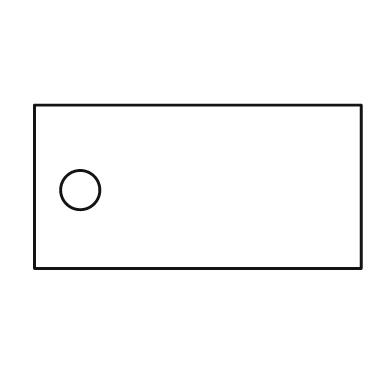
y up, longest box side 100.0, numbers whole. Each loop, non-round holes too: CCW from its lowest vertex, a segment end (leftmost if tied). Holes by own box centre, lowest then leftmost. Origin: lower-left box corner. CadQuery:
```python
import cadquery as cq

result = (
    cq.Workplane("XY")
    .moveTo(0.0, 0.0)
    .lineTo(100.0, 0.0)
    .lineTo(100.0, 50.0)
    .lineTo(0.0, 50.0)
    .close()
    .moveTo(14.0, 24.0)
    .circle(6.0)
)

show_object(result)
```